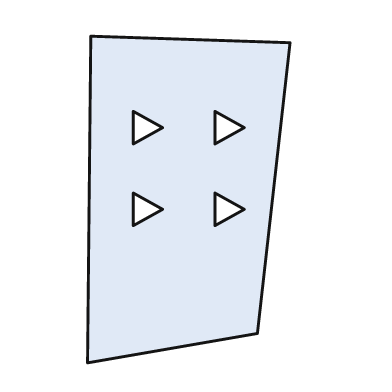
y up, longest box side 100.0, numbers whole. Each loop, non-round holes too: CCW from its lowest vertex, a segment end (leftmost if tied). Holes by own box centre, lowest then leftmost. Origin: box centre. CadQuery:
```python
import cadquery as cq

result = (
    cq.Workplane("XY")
    .moveTo(-31.0, -50.0)
    .lineTo(21.0, -41.0)
    .lineTo(31.0, 48.0)
    .lineTo(-30.0, 50.0)
    .close()
    .moveTo(-17.0, -8.0)
    .lineTo(-8.0, -3.0)
    .lineTo(-17.0, 2.0)
    .close()
    .moveTo(8.0, -8.0)
    .lineTo(17.0, -3.0)
    .lineTo(8.0, 2.0)
    .close()
    .moveTo(-17.0, 17.0)
    .lineTo(-8.0, 22.0)
    .lineTo(-17.0, 27.0)
    .close()
    .moveTo(8.0, 17.0)
    .lineTo(17.0, 22.0)
    .lineTo(8.0, 27.0)
    .close()
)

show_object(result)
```